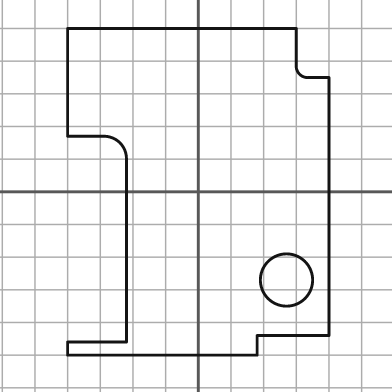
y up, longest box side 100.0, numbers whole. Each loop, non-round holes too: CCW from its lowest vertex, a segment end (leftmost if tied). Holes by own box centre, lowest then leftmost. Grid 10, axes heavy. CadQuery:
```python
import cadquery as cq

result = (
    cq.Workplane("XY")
    .moveTo(-40.0, -50.0)
    .lineTo(18.0, -50.0)
    .lineTo(18.0, -44.0)
    .lineTo(40.0, -44.0)
    .lineTo(40.0, 35.0)
    .lineTo(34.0, 35.0)
    .threePointArc((31.0, 36.0), (30.0, 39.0))
    .lineTo(30.0, 50.0)
    .lineTo(-40.0, 50.0)
    .lineTo(-40.0, 17.0)
    .lineTo(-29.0, 17.0)
    .threePointArc((-24.0, 15.0), (-22.0, 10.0))
    .lineTo(-22.0, -46.0)
    .lineTo(-40.0, -46.0)
    .close()
    .moveTo(27.0, -27.0)
    .circle(8.0)
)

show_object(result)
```